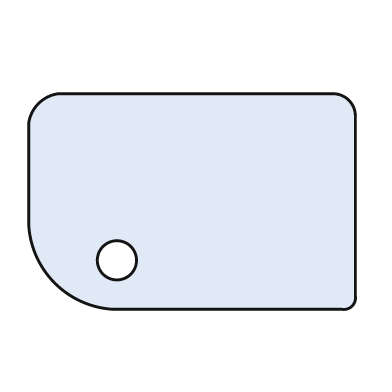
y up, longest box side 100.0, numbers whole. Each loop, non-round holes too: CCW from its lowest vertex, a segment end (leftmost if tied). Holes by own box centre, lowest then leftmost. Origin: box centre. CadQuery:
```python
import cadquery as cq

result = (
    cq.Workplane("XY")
    .moveTo(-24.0, -33.0)
    .lineTo(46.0, -33.0)
    .threePointArc((49.0, -32.0), (50.0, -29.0))
    .lineTo(50.0, 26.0)
    .threePointArc((48.0, 31.0), (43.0, 33.0))
    .lineTo(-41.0, 33.0)
    .threePointArc((-47.0, 30.0), (-50.0, 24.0))
    .lineTo(-50.0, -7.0)
    .threePointArc((-42.0, -25.0), (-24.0, -33.0))
    .close()
    .moveTo(-23.0, -18.0)
    .circle(6.0)
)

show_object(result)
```